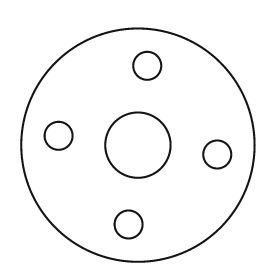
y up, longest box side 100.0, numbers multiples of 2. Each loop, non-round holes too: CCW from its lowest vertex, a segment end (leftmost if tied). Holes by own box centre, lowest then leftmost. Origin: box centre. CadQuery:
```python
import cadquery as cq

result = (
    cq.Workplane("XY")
    .moveTo(0.0, 0.0)
    .circle(50.0)
    .moveTo(-4.0, -34.0)
    .circle(6.0)
    .moveTo(34.0, -4.0)
    .circle(6.0)
    .moveTo(0.0, 0.0)
    .circle(14.0)
    .moveTo(-34.0, 4.0)
    .circle(6.0)
    .moveTo(4.0, 34.0)
    .circle(6.0)
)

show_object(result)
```